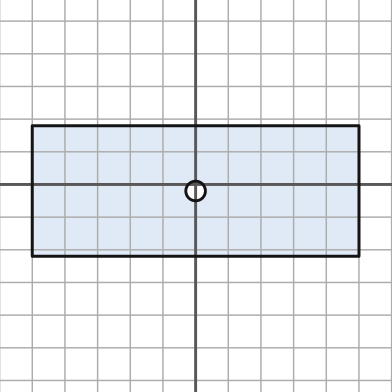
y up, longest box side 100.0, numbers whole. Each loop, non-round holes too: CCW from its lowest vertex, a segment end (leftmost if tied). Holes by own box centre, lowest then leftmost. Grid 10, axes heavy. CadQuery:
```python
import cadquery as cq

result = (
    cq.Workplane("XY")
    .moveTo(-50.0, -22.0)
    .lineTo(50.0, -22.0)
    .lineTo(50.0, 18.0)
    .lineTo(-50.0, 18.0)
    .close()
    .moveTo(0.0, -2.0)
    .circle(3.0)
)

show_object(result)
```